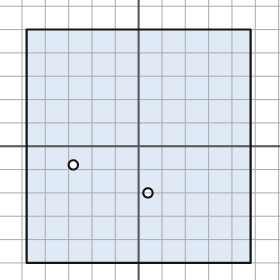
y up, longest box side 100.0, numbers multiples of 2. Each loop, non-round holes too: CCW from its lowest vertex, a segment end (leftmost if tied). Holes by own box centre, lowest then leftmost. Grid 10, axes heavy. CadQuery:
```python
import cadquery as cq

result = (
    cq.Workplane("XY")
    .moveTo(-48.0, -50.0)
    .lineTo(48.0, -50.0)
    .lineTo(48.0, 50.0)
    .lineTo(-48.0, 50.0)
    .close()
    .moveTo(4.0, -20.0)
    .circle(2.0)
    .moveTo(-28.0, -8.0)
    .circle(2.0)
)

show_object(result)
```